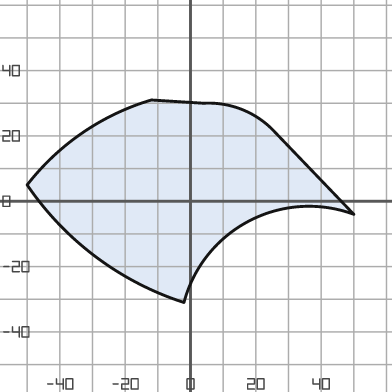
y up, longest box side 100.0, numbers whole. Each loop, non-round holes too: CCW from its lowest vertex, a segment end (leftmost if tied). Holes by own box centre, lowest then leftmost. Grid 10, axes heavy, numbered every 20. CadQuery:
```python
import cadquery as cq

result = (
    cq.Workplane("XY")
    .moveTo(-2.0, -31.0)
    .threePointArc((18.0, -6.0), (50.0, -4.0))
    .lineTo(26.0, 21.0)
    .threePointArc((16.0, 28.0), (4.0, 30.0))
    .lineTo(-12.0, 31.0)
    .threePointArc((-33.0, 21.0), (-50.0, 5.0))
    .threePointArc((-29.0, -17.0), (-2.0, -31.0))
    .close()
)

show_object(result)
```